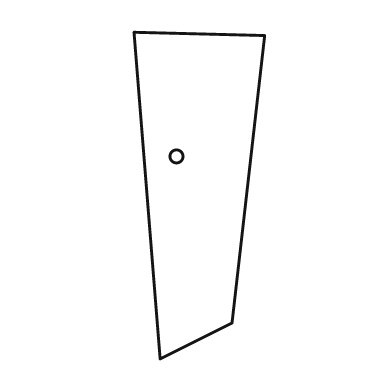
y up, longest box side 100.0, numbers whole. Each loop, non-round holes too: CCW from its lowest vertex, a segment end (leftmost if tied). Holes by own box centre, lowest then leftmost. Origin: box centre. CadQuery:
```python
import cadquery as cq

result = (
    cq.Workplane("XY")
    .moveTo(-12.0, -50.0)
    .lineTo(10.0, -39.0)
    .lineTo(20.0, 49.0)
    .lineTo(-20.0, 50.0)
    .close()
    .moveTo(-7.0, 12.0)
    .circle(2.0)
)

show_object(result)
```